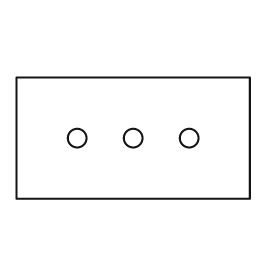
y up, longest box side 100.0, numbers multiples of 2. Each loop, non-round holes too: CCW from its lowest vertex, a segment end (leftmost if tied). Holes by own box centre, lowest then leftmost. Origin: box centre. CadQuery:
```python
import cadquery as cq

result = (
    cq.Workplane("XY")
    .moveTo(-50.0, -26.0)
    .lineTo(50.0, -26.0)
    .lineTo(50.0, 26.0)
    .lineTo(-50.0, 26.0)
    .close()
    .moveTo(-24.0, 0.0)
    .circle(4.0)
    .moveTo(0.0, 0.0)
    .circle(4.0)
    .moveTo(24.0, 0.0)
    .circle(4.0)
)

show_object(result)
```